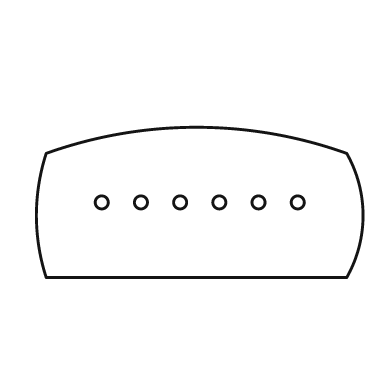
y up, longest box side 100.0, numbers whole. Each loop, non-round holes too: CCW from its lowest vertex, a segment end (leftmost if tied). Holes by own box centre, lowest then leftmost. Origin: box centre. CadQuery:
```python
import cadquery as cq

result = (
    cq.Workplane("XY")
    .moveTo(-47.0, -23.0)
    .lineTo(45.0, -23.0)
    .threePointArc((50.0, -4.0), (45.0, 15.0))
    .threePointArc((-1.0, 23.0), (-47.0, 15.0))
    .threePointArc((-50.0, -4.0), (-47.0, -23.0))
    .close()
    .moveTo(-30.0, 0.0)
    .circle(2.0)
    .moveTo(-18.0, 0.0)
    .circle(2.0)
    .moveTo(-6.0, 0.0)
    .circle(2.0)
    .moveTo(6.0, 0.0)
    .circle(2.0)
    .moveTo(18.0, 0.0)
    .circle(2.0)
    .moveTo(30.0, 0.0)
    .circle(2.0)
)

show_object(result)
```